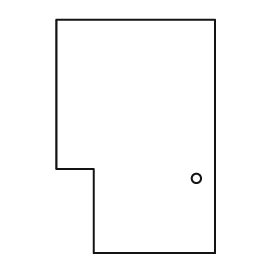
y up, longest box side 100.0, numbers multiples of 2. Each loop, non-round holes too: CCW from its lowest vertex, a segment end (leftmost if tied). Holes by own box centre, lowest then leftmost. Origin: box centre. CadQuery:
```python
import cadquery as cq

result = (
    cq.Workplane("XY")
    .moveTo(-18.0, -50.0)
    .lineTo(34.0, -50.0)
    .lineTo(34.0, 50.0)
    .lineTo(-34.0, 50.0)
    .lineTo(-34.0, -14.0)
    .lineTo(-18.0, -14.0)
    .close()
    .moveTo(26.0, -18.0)
    .circle(2.0)
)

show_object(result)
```